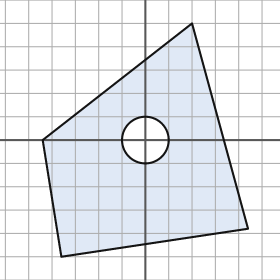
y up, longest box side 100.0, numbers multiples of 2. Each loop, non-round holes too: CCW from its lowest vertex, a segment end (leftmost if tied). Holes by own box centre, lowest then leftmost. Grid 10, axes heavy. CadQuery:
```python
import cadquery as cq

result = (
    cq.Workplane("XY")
    .moveTo(-36.0, -50.0)
    .lineTo(44.0, -38.0)
    .lineTo(20.0, 50.0)
    .lineTo(-44.0, 0.0)
    .close()
    .moveTo(0.0, 0.0)
    .circle(10.0)
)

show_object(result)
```